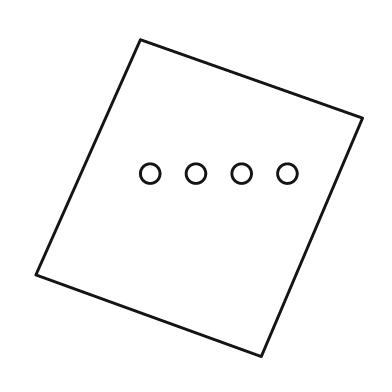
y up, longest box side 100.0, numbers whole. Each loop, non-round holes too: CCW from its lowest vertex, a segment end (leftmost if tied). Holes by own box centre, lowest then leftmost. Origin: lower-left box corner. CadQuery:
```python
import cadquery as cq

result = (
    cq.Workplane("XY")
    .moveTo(69.0, 0.0)
    .lineTo(100.0, 73.0)
    .lineTo(32.0, 97.0)
    .lineTo(0.0, 25.0)
    .close()
    .moveTo(35.0, 56.0)
    .circle(3.0)
    .moveTo(49.0, 56.0)
    .circle(3.0)
    .moveTo(63.0, 56.0)
    .circle(3.0)
    .moveTo(77.0, 56.0)
    .circle(3.0)
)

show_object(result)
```